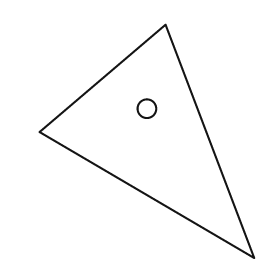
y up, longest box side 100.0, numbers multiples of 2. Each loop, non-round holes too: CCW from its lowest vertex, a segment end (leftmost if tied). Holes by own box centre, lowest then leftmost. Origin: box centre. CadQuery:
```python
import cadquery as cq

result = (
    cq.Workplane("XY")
    .moveTo(46.0, -50.0)
    .lineTo(8.0, 50.0)
    .lineTo(-46.0, 4.0)
    .close()
    .moveTo(0.0, 14.0)
    .circle(4.0)
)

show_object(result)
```